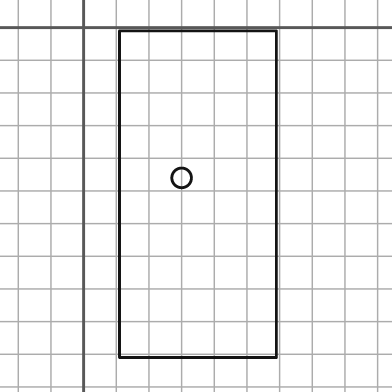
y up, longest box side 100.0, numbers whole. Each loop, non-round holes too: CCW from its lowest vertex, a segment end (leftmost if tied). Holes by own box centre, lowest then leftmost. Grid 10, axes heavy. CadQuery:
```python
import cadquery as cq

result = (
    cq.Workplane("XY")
    .moveTo(11.0, -101.0)
    .lineTo(59.0, -101.0)
    .lineTo(59.0, -1.0)
    .lineTo(11.0, -1.0)
    .close()
    .moveTo(30.0, -46.0)
    .circle(3.0)
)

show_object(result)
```